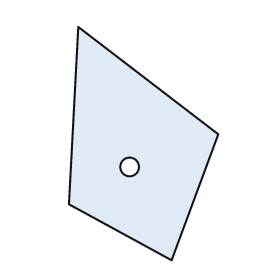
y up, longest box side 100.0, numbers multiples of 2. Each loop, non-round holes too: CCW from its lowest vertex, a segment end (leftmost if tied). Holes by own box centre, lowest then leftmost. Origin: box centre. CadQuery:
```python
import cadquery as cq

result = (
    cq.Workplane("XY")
    .moveTo(12.0, -50.0)
    .lineTo(32.0, 4.0)
    .lineTo(-28.0, 50.0)
    .lineTo(-32.0, -26.0)
    .close()
    .moveTo(-6.0, -10.0)
    .circle(4.0)
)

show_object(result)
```